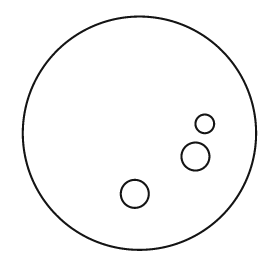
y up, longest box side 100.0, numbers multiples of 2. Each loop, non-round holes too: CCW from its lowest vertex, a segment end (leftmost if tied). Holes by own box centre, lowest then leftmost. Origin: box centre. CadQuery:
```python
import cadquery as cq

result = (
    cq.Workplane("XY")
    .moveTo(0.0, 0.0)
    .circle(50.0)
    .moveTo(-2.0, -26.0)
    .circle(6.0)
    .moveTo(24.0, -10.0)
    .circle(6.0)
    .moveTo(28.0, 4.0)
    .circle(4.0)
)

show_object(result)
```